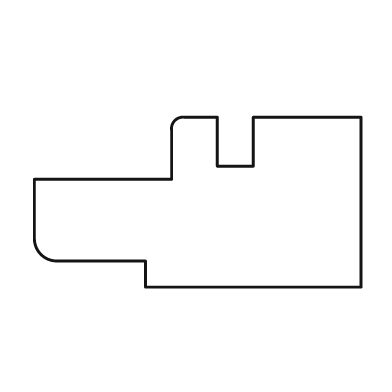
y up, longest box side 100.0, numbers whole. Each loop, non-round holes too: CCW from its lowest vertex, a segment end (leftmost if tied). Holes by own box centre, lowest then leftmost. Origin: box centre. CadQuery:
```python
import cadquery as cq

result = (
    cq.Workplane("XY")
    .moveTo(-16.0, -26.0)
    .lineTo(50.0, -26.0)
    .lineTo(50.0, 26.0)
    .lineTo(17.0, 26.0)
    .lineTo(17.0, 11.0)
    .lineTo(6.0, 11.0)
    .lineTo(6.0, 26.0)
    .lineTo(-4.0, 26.0)
    .threePointArc((-7.0, 25.0), (-8.0, 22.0))
    .lineTo(-8.0, 7.0)
    .lineTo(-50.0, 7.0)
    .lineTo(-50.0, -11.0)
    .threePointArc((-48.0, -16.0), (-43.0, -18.0))
    .lineTo(-16.0, -18.0)
    .close()
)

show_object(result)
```